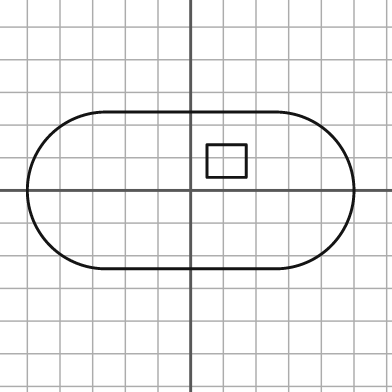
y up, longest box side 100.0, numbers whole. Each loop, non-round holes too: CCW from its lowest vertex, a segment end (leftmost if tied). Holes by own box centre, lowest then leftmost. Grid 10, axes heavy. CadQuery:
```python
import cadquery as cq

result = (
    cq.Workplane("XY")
    .moveTo(-26.0, -24.0)
    .lineTo(26.0, -24.0)
    .threePointArc((50.0, 0.0), (26.0, 24.0))
    .lineTo(-26.0, 24.0)
    .threePointArc((-50.0, 0.0), (-26.0, -24.0))
    .close()
    .moveTo(5.0, 4.0)
    .lineTo(17.0, 4.0)
    .lineTo(17.0, 14.0)
    .lineTo(5.0, 14.0)
    .close()
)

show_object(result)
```